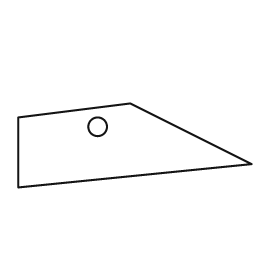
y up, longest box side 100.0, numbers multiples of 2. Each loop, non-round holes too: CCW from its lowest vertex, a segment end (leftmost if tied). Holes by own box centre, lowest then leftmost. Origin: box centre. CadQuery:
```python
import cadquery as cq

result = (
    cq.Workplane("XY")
    .moveTo(-50.0, -18.0)
    .lineTo(50.0, -8.0)
    .lineTo(-2.0, 18.0)
    .lineTo(-50.0, 12.0)
    .close()
    .moveTo(-16.0, 8.0)
    .circle(4.0)
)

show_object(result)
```